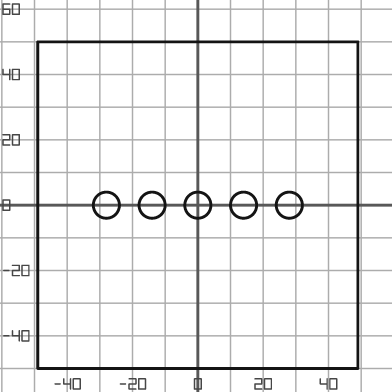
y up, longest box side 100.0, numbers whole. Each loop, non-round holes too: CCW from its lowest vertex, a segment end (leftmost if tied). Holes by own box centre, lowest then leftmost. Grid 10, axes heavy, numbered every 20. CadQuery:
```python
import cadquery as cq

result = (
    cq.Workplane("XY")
    .moveTo(-49.0, -50.0)
    .lineTo(49.0, -50.0)
    .lineTo(49.0, 50.0)
    .lineTo(-49.0, 50.0)
    .close()
    .moveTo(-28.0, 0.0)
    .circle(4.0)
    .moveTo(-14.0, 0.0)
    .circle(4.0)
    .moveTo(0.0, 0.0)
    .circle(4.0)
    .moveTo(14.0, 0.0)
    .circle(4.0)
    .moveTo(28.0, 0.0)
    .circle(4.0)
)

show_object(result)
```